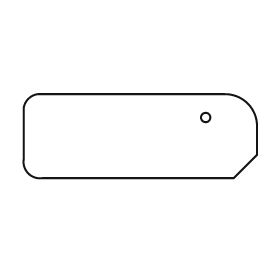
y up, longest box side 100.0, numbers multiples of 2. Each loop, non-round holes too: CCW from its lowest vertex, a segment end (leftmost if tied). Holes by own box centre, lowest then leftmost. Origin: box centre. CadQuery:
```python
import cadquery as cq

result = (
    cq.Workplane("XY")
    .moveTo(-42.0, -18.0)
    .lineTo(40.0, -18.0)
    .lineTo(50.0, -8.0)
    .lineTo(50.0, 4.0)
    .threePointArc((46.0, 14.0), (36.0, 18.0))
    .lineTo(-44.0, 18.0)
    .threePointArc((-48.0, 16.0), (-50.0, 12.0))
    .lineTo(-50.0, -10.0)
    .threePointArc((-48.0, -16.0), (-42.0, -18.0))
    .close()
    .moveTo(28.0, 8.0)
    .circle(2.0)
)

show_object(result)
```